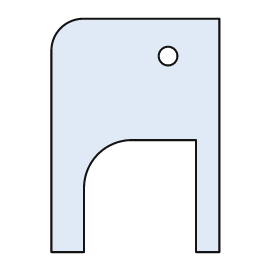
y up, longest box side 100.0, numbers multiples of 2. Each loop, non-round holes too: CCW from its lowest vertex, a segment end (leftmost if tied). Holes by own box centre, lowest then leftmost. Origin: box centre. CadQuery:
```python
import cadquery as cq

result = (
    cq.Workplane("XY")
    .moveTo(-36.0, -50.0)
    .lineTo(-22.0, -50.0)
    .lineTo(-22.0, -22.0)
    .threePointArc((-16.0, -8.0), (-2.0, -2.0))
    .lineTo(26.0, -2.0)
    .lineTo(26.0, -50.0)
    .lineTo(36.0, -50.0)
    .lineTo(36.0, 50.0)
    .lineTo(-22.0, 50.0)
    .threePointArc((-32.0, 46.0), (-36.0, 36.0))
    .close()
    .moveTo(14.0, 34.0)
    .circle(4.0)
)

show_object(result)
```